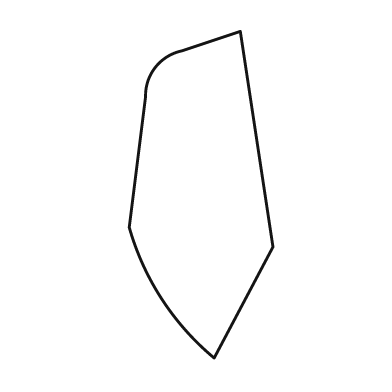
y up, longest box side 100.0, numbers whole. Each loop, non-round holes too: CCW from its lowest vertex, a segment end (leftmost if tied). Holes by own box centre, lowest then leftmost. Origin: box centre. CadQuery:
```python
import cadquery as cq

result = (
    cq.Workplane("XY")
    .moveTo(4.0, -50.0)
    .lineTo(22.0, -16.0)
    .lineTo(12.0, 50.0)
    .lineTo(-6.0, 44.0)
    .threePointArc((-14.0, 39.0), (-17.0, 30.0))
    .lineTo(-22.0, -10.0)
    .threePointArc((-12.0, -32.0), (4.0, -50.0))
    .close()
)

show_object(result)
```